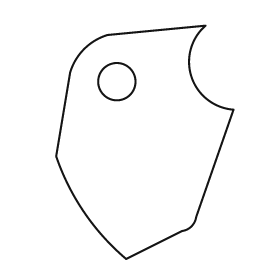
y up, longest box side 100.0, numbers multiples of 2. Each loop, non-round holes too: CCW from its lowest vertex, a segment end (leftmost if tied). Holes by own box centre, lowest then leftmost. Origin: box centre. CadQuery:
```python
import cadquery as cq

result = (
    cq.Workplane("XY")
    .moveTo(-8.0, -50.0)
    .lineTo(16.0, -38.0)
    .threePointArc((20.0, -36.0), (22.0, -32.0))
    .lineTo(38.0, 14.0)
    .threePointArc((20.0, 28.0), (26.0, 50.0))
    .lineTo(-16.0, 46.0)
    .threePointArc((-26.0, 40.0), (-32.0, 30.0))
    .lineTo(-38.0, -6.0)
    .threePointArc((-26.0, -30.0), (-8.0, -50.0))
    .close()
    .moveTo(-12.0, 26.0)
    .circle(8.0)
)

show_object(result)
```